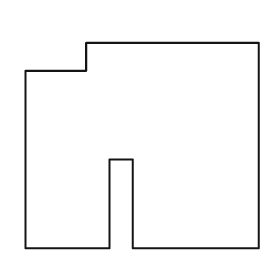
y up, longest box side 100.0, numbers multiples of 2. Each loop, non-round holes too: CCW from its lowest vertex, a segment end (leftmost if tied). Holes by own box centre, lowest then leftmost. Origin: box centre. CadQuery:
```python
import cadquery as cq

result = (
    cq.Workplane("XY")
    .moveTo(-50.0, -44.0)
    .lineTo(-14.0, -44.0)
    .lineTo(-14.0, -6.0)
    .lineTo(-4.0, -6.0)
    .lineTo(-4.0, -44.0)
    .lineTo(50.0, -44.0)
    .lineTo(50.0, 44.0)
    .lineTo(-24.0, 44.0)
    .lineTo(-24.0, 32.0)
    .lineTo(-50.0, 32.0)
    .close()
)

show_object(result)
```